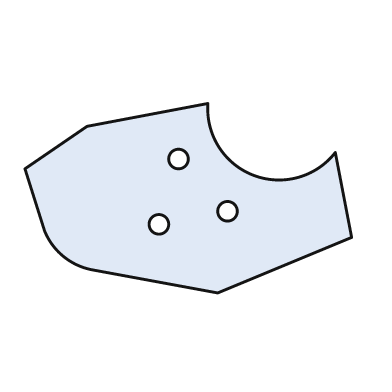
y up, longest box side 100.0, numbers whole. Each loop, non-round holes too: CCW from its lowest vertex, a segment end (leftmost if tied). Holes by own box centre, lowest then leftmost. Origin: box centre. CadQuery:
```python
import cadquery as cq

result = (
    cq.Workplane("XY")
    .moveTo(9.0, -29.0)
    .lineTo(50.0, -12.0)
    .lineTo(45.0, 14.0)
    .threePointArc((20.0, 7.0), (6.0, 29.0))
    .lineTo(-31.0, 22.0)
    .lineTo(-50.0, 9.0)
    .lineTo(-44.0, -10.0)
    .threePointArc((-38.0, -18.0), (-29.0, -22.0))
    .close()
    .moveTo(-9.0, -8.0)
    .circle(3.0)
    .moveTo(12.0, -4.0)
    .circle(3.0)
    .moveTo(-3.0, 12.0)
    .circle(3.0)
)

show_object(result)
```